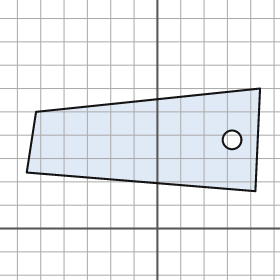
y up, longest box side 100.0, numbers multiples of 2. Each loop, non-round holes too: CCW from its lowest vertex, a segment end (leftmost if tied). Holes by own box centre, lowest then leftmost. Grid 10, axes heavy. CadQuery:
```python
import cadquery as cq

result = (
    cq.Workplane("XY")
    .moveTo(42.0, 16.0)
    .lineTo(44.0, 60.0)
    .lineTo(-52.0, 50.0)
    .lineTo(-56.0, 24.0)
    .close()
    .moveTo(32.0, 38.0)
    .circle(4.0)
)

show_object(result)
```